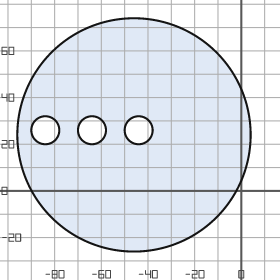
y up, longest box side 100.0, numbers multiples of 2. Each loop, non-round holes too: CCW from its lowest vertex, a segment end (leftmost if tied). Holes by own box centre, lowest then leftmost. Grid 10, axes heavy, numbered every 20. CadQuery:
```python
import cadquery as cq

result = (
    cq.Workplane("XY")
    .moveTo(-46.0, 24.0)
    .circle(50.0)
    .moveTo(-84.0, 26.0)
    .circle(6.0)
    .moveTo(-64.0, 26.0)
    .circle(6.0)
    .moveTo(-44.0, 26.0)
    .circle(6.0)
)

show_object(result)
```